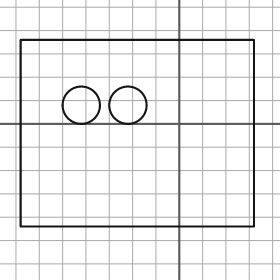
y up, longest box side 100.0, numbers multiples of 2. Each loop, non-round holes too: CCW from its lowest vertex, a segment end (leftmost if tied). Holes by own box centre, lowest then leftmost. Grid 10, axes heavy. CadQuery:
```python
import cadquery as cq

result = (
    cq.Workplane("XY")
    .moveTo(-68.0, -44.0)
    .lineTo(32.0, -44.0)
    .lineTo(32.0, 36.0)
    .lineTo(-68.0, 36.0)
    .close()
    .moveTo(-42.0, 8.0)
    .circle(8.0)
    .moveTo(-22.0, 8.0)
    .circle(8.0)
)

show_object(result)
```